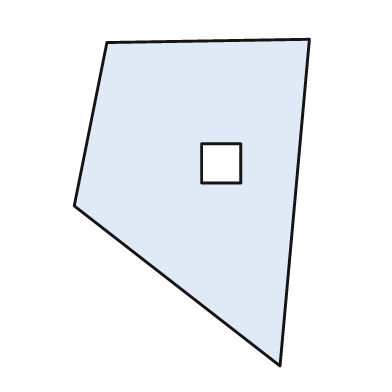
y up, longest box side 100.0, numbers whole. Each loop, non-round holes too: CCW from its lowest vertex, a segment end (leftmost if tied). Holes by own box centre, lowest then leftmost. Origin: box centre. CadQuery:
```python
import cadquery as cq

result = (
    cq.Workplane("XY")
    .moveTo(27.0, -50.0)
    .lineTo(36.0, 50.0)
    .lineTo(-26.0, 49.0)
    .lineTo(-36.0, -1.0)
    .close()
    .moveTo(3.0, 6.0)
    .lineTo(15.0, 6.0)
    .lineTo(15.0, 18.0)
    .lineTo(3.0, 18.0)
    .close()
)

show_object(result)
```